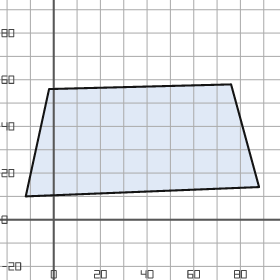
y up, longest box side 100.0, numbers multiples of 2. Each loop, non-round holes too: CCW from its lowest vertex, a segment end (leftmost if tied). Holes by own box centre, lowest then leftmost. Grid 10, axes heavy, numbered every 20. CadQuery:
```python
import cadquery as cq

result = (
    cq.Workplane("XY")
    .moveTo(-12.0, 10.0)
    .lineTo(88.0, 14.0)
    .lineTo(76.0, 58.0)
    .lineTo(-2.0, 56.0)
    .close()
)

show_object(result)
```